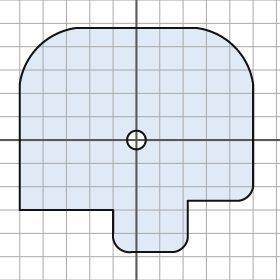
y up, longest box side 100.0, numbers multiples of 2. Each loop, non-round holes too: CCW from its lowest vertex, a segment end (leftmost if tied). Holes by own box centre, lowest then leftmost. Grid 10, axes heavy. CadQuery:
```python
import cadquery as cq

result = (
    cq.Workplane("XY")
    .moveTo(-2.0, -48.0)
    .lineTo(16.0, -48.0)
    .threePointArc((20.0, -46.0), (22.0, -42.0))
    .lineTo(22.0, -26.0)
    .lineTo(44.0, -26.0)
    .threePointArc((48.0, -24.0), (50.0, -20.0))
    .lineTo(50.0, 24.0)
    .threePointArc((42.0, 40.0), (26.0, 48.0))
    .lineTo(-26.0, 48.0)
    .threePointArc((-42.0, 40.0), (-50.0, 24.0))
    .lineTo(-50.0, -30.0)
    .lineTo(-10.0, -30.0)
    .lineTo(-10.0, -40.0)
    .threePointArc((-8.0, -46.0), (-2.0, -48.0))
    .close()
    .moveTo(0.0, 0.0)
    .circle(4.0)
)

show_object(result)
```